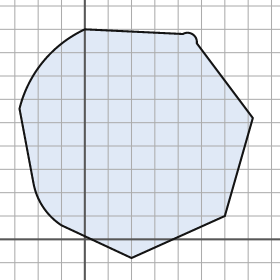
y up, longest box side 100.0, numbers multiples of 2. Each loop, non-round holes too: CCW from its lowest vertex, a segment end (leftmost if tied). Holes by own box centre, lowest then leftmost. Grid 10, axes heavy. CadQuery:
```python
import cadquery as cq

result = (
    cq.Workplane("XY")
    .moveTo(20.0, -8.0)
    .lineTo(60.0, 10.0)
    .lineTo(72.0, 52.0)
    .lineTo(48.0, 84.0)
    .threePointArc((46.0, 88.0), (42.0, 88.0))
    .lineTo(0.0, 90.0)
    .threePointArc((-18.0, 76.0), (-28.0, 56.0))
    .lineTo(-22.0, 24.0)
    .threePointArc((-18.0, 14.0), (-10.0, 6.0))
    .close()
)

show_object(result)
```